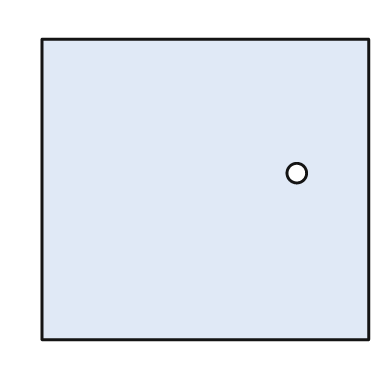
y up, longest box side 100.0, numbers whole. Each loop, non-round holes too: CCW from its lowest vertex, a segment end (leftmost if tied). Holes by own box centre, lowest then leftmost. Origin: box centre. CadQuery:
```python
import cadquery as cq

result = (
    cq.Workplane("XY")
    .moveTo(-50.0, -46.0)
    .lineTo(50.0, -46.0)
    .lineTo(50.0, 46.0)
    .lineTo(-50.0, 46.0)
    .close()
    .moveTo(28.0, 5.0)
    .circle(3.0)
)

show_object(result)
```